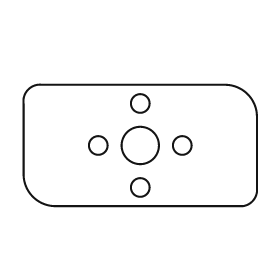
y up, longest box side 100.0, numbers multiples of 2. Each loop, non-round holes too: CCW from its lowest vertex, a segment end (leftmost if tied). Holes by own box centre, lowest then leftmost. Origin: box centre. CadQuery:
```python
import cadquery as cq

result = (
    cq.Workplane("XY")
    .moveTo(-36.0, -26.0)
    .lineTo(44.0, -26.0)
    .threePointArc((48.0, -24.0), (50.0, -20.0))
    .lineTo(50.0, 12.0)
    .threePointArc((46.0, 22.0), (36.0, 26.0))
    .lineTo(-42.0, 26.0)
    .threePointArc((-48.0, 24.0), (-50.0, 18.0))
    .lineTo(-50.0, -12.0)
    .threePointArc((-46.0, -22.0), (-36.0, -26.0))
    .close()
    .moveTo(0.0, -18.0)
    .circle(4.0)
    .moveTo(-18.0, 0.0)
    .circle(4.0)
    .moveTo(0.0, 0.0)
    .circle(8.0)
    .moveTo(18.0, 0.0)
    .circle(4.0)
    .moveTo(0.0, 18.0)
    .circle(4.0)
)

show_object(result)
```